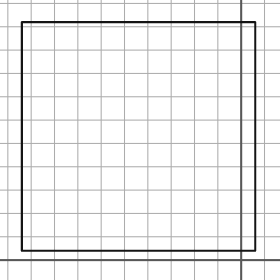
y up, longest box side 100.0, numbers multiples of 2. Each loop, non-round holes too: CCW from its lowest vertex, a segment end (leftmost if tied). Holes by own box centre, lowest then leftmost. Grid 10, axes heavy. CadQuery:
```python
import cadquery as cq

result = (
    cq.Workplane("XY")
    .moveTo(-94.0, 4.0)
    .lineTo(6.0, 4.0)
    .lineTo(6.0, 102.0)
    .lineTo(-94.0, 102.0)
    .close()
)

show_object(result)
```